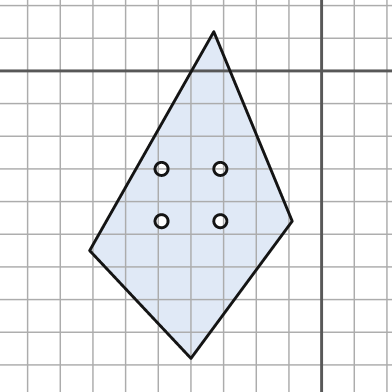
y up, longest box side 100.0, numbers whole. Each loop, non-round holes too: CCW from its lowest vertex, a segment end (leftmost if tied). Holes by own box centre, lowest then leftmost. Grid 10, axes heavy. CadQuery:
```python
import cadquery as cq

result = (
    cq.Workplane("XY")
    .moveTo(-40.0, -88.0)
    .lineTo(-9.0, -46.0)
    .lineTo(-33.0, 12.0)
    .lineTo(-71.0, -55.0)
    .close()
    .moveTo(-49.0, -46.0)
    .circle(2.0)
    .moveTo(-31.0, -46.0)
    .circle(2.0)
    .moveTo(-49.0, -30.0)
    .circle(2.0)
    .moveTo(-31.0, -30.0)
    .circle(2.0)
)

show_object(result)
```